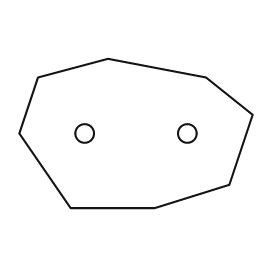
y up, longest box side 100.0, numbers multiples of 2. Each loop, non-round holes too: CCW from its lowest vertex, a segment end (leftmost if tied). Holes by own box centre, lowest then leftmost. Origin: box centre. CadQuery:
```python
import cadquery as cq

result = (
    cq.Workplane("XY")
    .moveTo(-28.0, -32.0)
    .lineTo(8.0, -32.0)
    .lineTo(40.0, -22.0)
    .lineTo(50.0, 8.0)
    .lineTo(30.0, 24.0)
    .lineTo(-12.0, 32.0)
    .lineTo(-42.0, 24.0)
    .lineTo(-50.0, 0.0)
    .close()
    .moveTo(-22.0, 0.0)
    .circle(4.0)
    .moveTo(22.0, 0.0)
    .circle(4.0)
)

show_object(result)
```